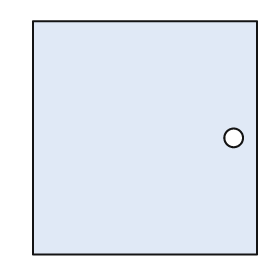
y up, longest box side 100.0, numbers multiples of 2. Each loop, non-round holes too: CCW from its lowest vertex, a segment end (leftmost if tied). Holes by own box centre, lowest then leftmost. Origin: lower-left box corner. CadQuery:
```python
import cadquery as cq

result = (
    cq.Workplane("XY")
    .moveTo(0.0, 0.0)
    .lineTo(96.0, 0.0)
    .lineTo(96.0, 100.0)
    .lineTo(0.0, 100.0)
    .close()
    .moveTo(86.0, 50.0)
    .circle(4.0)
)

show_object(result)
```